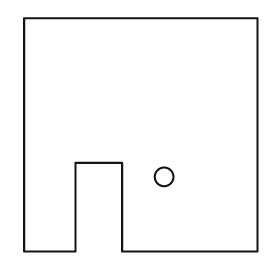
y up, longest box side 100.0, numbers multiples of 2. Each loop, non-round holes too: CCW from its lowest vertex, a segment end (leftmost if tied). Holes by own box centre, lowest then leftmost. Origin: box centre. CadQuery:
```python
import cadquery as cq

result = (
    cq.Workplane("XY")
    .moveTo(-50.0, -50.0)
    .lineTo(-28.0, -50.0)
    .lineTo(-28.0, -12.0)
    .lineTo(-8.0, -12.0)
    .lineTo(-8.0, -50.0)
    .lineTo(50.0, -50.0)
    .lineTo(50.0, 50.0)
    .lineTo(-50.0, 50.0)
    .close()
    .moveTo(10.0, -18.0)
    .circle(4.0)
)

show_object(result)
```